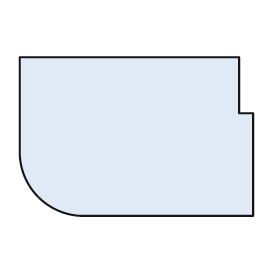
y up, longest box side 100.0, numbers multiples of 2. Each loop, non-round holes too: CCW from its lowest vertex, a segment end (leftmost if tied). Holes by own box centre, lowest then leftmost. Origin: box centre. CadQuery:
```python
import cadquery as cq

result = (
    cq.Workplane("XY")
    .moveTo(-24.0, -34.0)
    .lineTo(50.0, -34.0)
    .lineTo(50.0, 10.0)
    .lineTo(44.0, 10.0)
    .lineTo(44.0, 34.0)
    .lineTo(-50.0, 34.0)
    .lineTo(-50.0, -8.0)
    .threePointArc((-42.0, -26.0), (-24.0, -34.0))
    .close()
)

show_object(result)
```